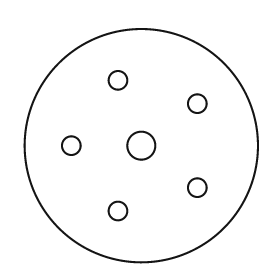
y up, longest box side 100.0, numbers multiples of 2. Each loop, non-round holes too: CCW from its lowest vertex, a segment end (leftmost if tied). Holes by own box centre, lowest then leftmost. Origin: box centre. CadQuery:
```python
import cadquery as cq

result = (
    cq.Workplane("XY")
    .moveTo(0.0, 0.0)
    .circle(50.0)
    .moveTo(-10.0, -28.0)
    .circle(4.0)
    .moveTo(24.0, -18.0)
    .circle(4.0)
    .moveTo(-30.0, 0.0)
    .circle(4.0)
    .moveTo(0.0, 0.0)
    .circle(6.0)
    .moveTo(24.0, 18.0)
    .circle(4.0)
    .moveTo(-10.0, 28.0)
    .circle(4.0)
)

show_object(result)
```